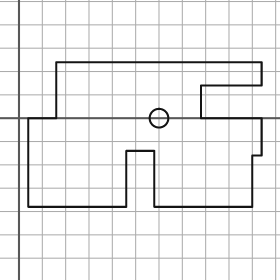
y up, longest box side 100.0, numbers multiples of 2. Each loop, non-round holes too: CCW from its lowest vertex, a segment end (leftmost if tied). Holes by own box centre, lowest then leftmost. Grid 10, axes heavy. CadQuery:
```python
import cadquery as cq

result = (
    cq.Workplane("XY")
    .moveTo(4.0, -38.0)
    .lineTo(46.0, -38.0)
    .lineTo(46.0, -14.0)
    .lineTo(58.0, -14.0)
    .lineTo(58.0, -38.0)
    .lineTo(100.0, -38.0)
    .lineTo(100.0, -16.0)
    .lineTo(104.0, -16.0)
    .lineTo(104.0, 0.0)
    .lineTo(78.0, 0.0)
    .lineTo(78.0, 14.0)
    .lineTo(104.0, 14.0)
    .lineTo(104.0, 24.0)
    .lineTo(16.0, 24.0)
    .lineTo(16.0, 0.0)
    .lineTo(4.0, 0.0)
    .close()
    .moveTo(60.0, 0.0)
    .circle(4.0)
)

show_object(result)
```